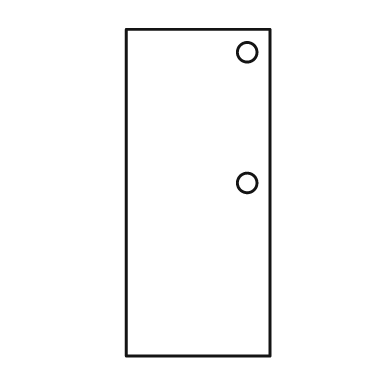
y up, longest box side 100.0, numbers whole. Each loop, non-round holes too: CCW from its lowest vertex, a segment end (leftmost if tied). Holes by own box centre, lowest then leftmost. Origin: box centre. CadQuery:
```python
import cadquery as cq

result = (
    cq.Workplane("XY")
    .moveTo(-22.0, -50.0)
    .lineTo(22.0, -50.0)
    .lineTo(22.0, 50.0)
    .lineTo(-22.0, 50.0)
    .close()
    .moveTo(15.0, 3.0)
    .circle(3.0)
    .moveTo(15.0, 43.0)
    .circle(3.0)
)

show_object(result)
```